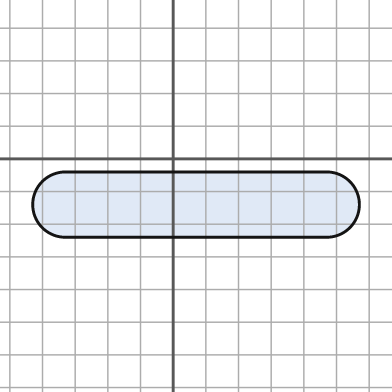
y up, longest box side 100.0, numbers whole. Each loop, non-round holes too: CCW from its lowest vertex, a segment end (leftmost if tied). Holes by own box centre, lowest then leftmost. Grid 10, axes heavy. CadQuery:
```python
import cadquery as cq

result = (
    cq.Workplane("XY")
    .moveTo(-33.0, -24.0)
    .lineTo(47.0, -24.0)
    .threePointArc((57.0, -14.0), (47.0, -4.0))
    .lineTo(-33.0, -4.0)
    .threePointArc((-43.0, -14.0), (-33.0, -24.0))
    .close()
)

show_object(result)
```